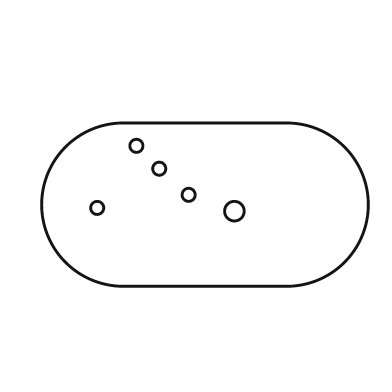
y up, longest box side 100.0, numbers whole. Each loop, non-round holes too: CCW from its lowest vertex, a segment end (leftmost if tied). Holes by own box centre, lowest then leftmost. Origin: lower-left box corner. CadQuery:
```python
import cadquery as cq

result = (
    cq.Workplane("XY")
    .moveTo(25.0, 0.0)
    .lineTo(75.0, 0.0)
    .threePointArc((100.0, 25.0), (75.0, 50.0))
    .lineTo(25.0, 50.0)
    .threePointArc((0.0, 25.0), (25.0, 0.0))
    .close()
    .moveTo(59.0, 23.0)
    .circle(3.0)
    .moveTo(17.0, 24.0)
    .circle(2.0)
    .moveTo(45.0, 28.0)
    .circle(2.0)
    .moveTo(36.0, 36.0)
    .circle(2.0)
    .moveTo(29.0, 43.0)
    .circle(2.0)
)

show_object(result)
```